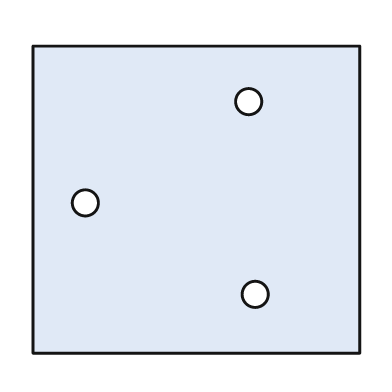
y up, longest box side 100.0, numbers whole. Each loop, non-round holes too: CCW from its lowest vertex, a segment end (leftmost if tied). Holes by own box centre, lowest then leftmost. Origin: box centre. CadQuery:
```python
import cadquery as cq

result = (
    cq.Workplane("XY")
    .moveTo(-50.0, -47.0)
    .lineTo(50.0, -47.0)
    .lineTo(50.0, 47.0)
    .lineTo(-50.0, 47.0)
    .close()
    .moveTo(18.0, -29.0)
    .circle(4.0)
    .moveTo(-34.0, -1.0)
    .circle(4.0)
    .moveTo(16.0, 30.0)
    .circle(4.0)
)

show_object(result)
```